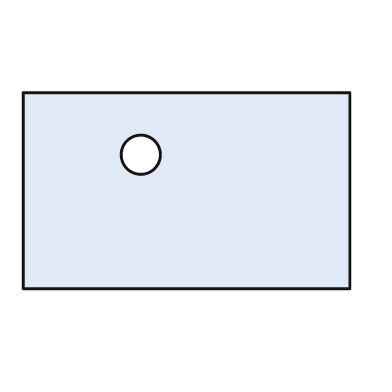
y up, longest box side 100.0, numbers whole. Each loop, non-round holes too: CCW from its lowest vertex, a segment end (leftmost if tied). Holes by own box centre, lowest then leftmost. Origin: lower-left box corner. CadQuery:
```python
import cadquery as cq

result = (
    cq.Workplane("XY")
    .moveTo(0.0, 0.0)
    .lineTo(100.0, 0.0)
    .lineTo(100.0, 60.0)
    .lineTo(0.0, 60.0)
    .close()
    .moveTo(36.0, 41.0)
    .circle(6.0)
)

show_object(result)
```